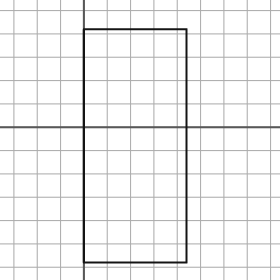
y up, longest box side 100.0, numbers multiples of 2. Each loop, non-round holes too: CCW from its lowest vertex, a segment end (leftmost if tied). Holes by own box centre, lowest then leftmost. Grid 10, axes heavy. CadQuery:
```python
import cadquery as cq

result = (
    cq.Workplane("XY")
    .moveTo(0.0, -58.0)
    .lineTo(44.0, -58.0)
    .lineTo(44.0, 42.0)
    .lineTo(0.0, 42.0)
    .close()
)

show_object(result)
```